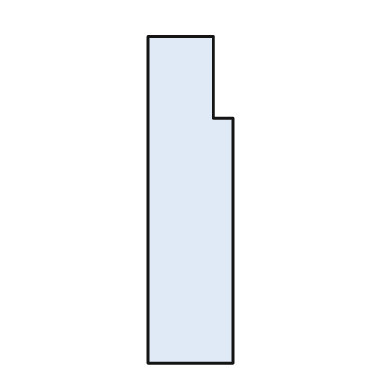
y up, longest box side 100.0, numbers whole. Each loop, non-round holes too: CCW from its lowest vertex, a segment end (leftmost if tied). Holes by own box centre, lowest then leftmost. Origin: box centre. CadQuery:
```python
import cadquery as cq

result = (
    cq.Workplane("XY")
    .moveTo(-13.0, -50.0)
    .lineTo(13.0, -50.0)
    .lineTo(13.0, 25.0)
    .lineTo(7.0, 25.0)
    .lineTo(7.0, 50.0)
    .lineTo(-13.0, 50.0)
    .close()
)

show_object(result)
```